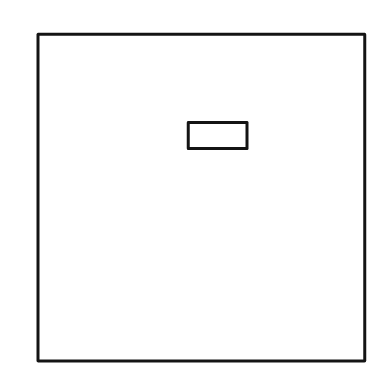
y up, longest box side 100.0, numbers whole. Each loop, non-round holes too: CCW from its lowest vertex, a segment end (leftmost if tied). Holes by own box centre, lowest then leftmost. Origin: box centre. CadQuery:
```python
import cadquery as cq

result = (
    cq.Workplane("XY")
    .moveTo(-50.0, -50.0)
    .lineTo(50.0, -50.0)
    .lineTo(50.0, 50.0)
    .lineTo(-50.0, 50.0)
    .close()
    .moveTo(-4.0, 15.0)
    .lineTo(14.0, 15.0)
    .lineTo(14.0, 23.0)
    .lineTo(-4.0, 23.0)
    .close()
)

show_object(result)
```